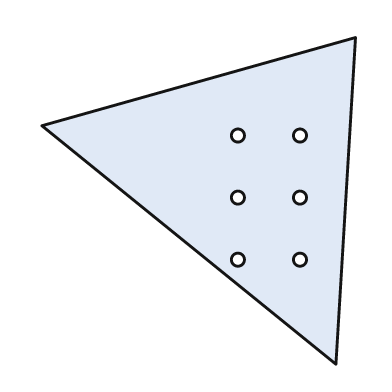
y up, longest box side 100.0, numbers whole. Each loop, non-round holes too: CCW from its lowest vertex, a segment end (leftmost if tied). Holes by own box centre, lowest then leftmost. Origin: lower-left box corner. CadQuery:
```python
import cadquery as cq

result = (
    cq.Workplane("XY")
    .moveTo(90.0, 0.0)
    .lineTo(96.0, 100.0)
    .lineTo(0.0, 73.0)
    .close()
    .moveTo(60.0, 32.0)
    .circle(2.0)
    .moveTo(79.0, 32.0)
    .circle(2.0)
    .moveTo(60.0, 51.0)
    .circle(2.0)
    .moveTo(79.0, 51.0)
    .circle(2.0)
    .moveTo(60.0, 70.0)
    .circle(2.0)
    .moveTo(79.0, 70.0)
    .circle(2.0)
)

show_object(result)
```